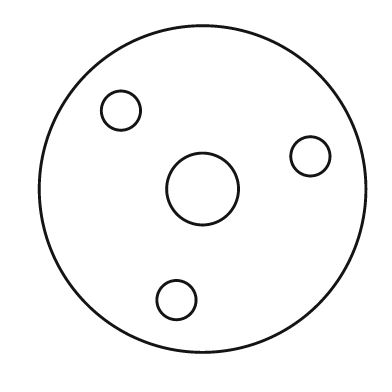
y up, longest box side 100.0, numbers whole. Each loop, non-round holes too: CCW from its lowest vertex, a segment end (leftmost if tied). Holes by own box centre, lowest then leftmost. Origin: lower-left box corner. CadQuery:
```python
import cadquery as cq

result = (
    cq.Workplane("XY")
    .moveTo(50.0, 50.0)
    .circle(50.0)
    .moveTo(42.0, 16.0)
    .circle(6.0)
    .moveTo(50.0, 50.0)
    .circle(11.0)
    .moveTo(83.0, 60.0)
    .circle(6.0)
    .moveTo(25.0, 74.0)
    .circle(6.0)
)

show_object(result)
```